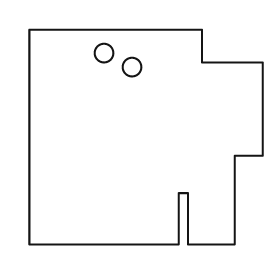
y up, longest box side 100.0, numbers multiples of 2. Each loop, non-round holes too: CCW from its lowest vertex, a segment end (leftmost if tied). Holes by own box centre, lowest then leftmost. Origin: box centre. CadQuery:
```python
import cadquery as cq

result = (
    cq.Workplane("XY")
    .moveTo(-50.0, -46.0)
    .lineTo(14.0, -46.0)
    .lineTo(14.0, -24.0)
    .lineTo(18.0, -24.0)
    .lineTo(18.0, -46.0)
    .lineTo(38.0, -46.0)
    .lineTo(38.0, -8.0)
    .lineTo(50.0, -8.0)
    .lineTo(50.0, 32.0)
    .lineTo(24.0, 32.0)
    .lineTo(24.0, 46.0)
    .lineTo(-50.0, 46.0)
    .close()
    .moveTo(-6.0, 30.0)
    .circle(4.0)
    .moveTo(-18.0, 36.0)
    .circle(4.0)
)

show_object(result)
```